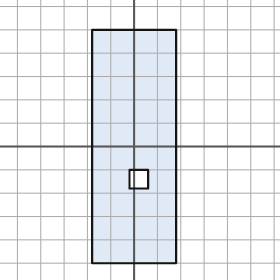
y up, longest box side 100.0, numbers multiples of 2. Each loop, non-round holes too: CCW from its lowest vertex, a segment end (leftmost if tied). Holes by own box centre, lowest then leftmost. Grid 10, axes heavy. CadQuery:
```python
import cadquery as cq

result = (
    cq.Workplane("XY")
    .moveTo(-18.0, -50.0)
    .lineTo(18.0, -50.0)
    .lineTo(18.0, 50.0)
    .lineTo(-18.0, 50.0)
    .close()
    .moveTo(-2.0, -18.0)
    .lineTo(6.0, -18.0)
    .lineTo(6.0, -10.0)
    .lineTo(-2.0, -10.0)
    .close()
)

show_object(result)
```